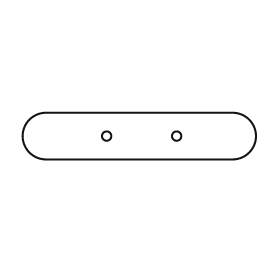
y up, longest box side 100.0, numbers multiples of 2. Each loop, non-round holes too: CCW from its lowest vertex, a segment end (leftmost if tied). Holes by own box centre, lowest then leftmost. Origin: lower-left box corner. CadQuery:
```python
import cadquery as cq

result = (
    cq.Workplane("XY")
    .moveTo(10.0, 0.0)
    .lineTo(90.0, 0.0)
    .threePointArc((100.0, 10.0), (90.0, 20.0))
    .lineTo(10.0, 20.0)
    .threePointArc((0.0, 10.0), (10.0, 0.0))
    .close()
    .moveTo(36.0, 10.0)
    .circle(2.0)
    .moveTo(66.0, 10.0)
    .circle(2.0)
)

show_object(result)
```